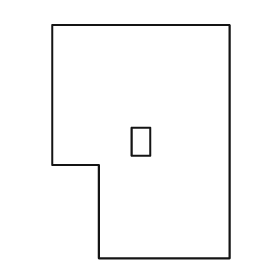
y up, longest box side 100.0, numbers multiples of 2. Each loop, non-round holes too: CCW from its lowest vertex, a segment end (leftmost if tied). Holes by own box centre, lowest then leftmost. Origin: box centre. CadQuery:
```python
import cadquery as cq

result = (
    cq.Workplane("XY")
    .moveTo(-18.0, -50.0)
    .lineTo(38.0, -50.0)
    .lineTo(38.0, 50.0)
    .lineTo(-38.0, 50.0)
    .lineTo(-38.0, -10.0)
    .lineTo(-18.0, -10.0)
    .close()
    .moveTo(-4.0, -6.0)
    .lineTo(4.0, -6.0)
    .lineTo(4.0, 6.0)
    .lineTo(-4.0, 6.0)
    .close()
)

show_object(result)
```